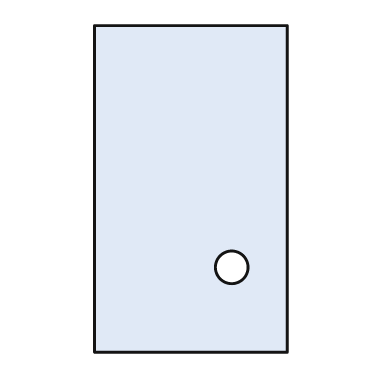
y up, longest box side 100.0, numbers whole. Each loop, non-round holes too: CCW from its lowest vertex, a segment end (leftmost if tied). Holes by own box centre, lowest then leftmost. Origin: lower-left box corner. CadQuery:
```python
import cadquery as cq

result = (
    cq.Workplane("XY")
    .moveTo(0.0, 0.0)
    .lineTo(59.0, 0.0)
    .lineTo(59.0, 100.0)
    .lineTo(0.0, 100.0)
    .close()
    .moveTo(42.0, 26.0)
    .circle(5.0)
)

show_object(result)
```